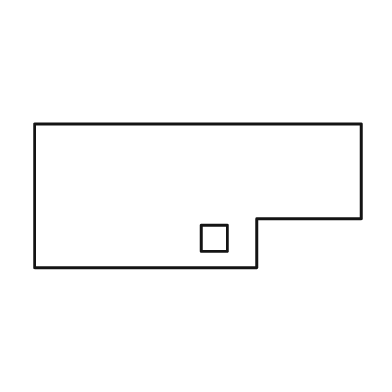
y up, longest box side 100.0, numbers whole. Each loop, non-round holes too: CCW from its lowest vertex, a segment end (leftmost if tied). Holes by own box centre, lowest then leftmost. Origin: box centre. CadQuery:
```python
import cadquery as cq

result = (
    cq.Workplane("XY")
    .moveTo(-50.0, -22.0)
    .lineTo(18.0, -22.0)
    .lineTo(18.0, -7.0)
    .lineTo(50.0, -7.0)
    .lineTo(50.0, 22.0)
    .lineTo(-50.0, 22.0)
    .close()
    .moveTo(1.0, -17.0)
    .lineTo(9.0, -17.0)
    .lineTo(9.0, -9.0)
    .lineTo(1.0, -9.0)
    .close()
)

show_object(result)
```